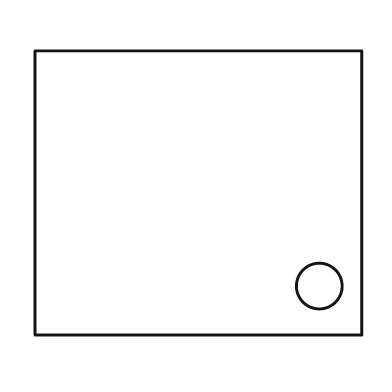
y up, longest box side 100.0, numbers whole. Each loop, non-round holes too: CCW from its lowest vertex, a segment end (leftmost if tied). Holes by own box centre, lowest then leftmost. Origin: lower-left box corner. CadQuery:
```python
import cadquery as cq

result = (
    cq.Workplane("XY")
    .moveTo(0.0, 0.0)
    .lineTo(100.0, 0.0)
    .lineTo(100.0, 87.0)
    .lineTo(0.0, 87.0)
    .close()
    .moveTo(87.0, 15.0)
    .circle(7.0)
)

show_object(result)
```